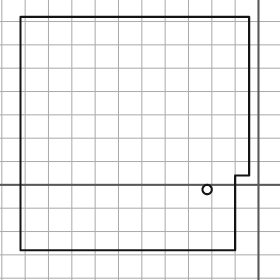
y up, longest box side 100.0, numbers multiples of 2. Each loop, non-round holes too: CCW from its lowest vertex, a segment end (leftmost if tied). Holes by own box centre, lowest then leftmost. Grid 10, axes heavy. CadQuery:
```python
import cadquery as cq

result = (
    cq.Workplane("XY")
    .moveTo(-102.0, -28.0)
    .lineTo(-10.0, -28.0)
    .lineTo(-10.0, 4.0)
    .lineTo(-4.0, 4.0)
    .lineTo(-4.0, 72.0)
    .lineTo(-102.0, 72.0)
    .close()
    .moveTo(-22.0, -2.0)
    .circle(2.0)
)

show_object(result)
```